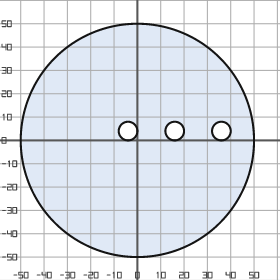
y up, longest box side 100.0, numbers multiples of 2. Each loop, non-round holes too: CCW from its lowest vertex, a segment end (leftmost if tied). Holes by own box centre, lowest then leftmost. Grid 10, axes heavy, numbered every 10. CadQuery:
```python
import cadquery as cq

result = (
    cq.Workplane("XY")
    .moveTo(0.0, 0.0)
    .circle(50.0)
    .moveTo(-4.0, 4.0)
    .circle(4.0)
    .moveTo(16.0, 4.0)
    .circle(4.0)
    .moveTo(36.0, 4.0)
    .circle(4.0)
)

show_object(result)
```